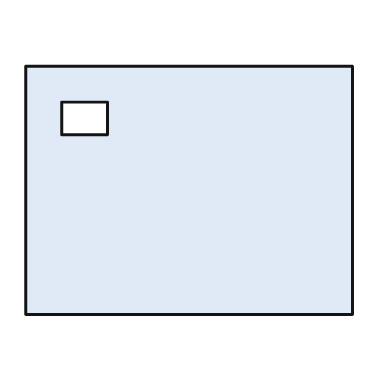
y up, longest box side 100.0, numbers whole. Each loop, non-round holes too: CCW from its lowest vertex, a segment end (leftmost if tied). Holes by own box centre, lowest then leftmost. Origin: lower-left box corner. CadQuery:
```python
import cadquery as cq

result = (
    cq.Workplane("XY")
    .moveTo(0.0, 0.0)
    .lineTo(100.0, 0.0)
    .lineTo(100.0, 76.0)
    .lineTo(0.0, 76.0)
    .close()
    .moveTo(11.0, 55.0)
    .lineTo(25.0, 55.0)
    .lineTo(25.0, 65.0)
    .lineTo(11.0, 65.0)
    .close()
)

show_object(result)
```